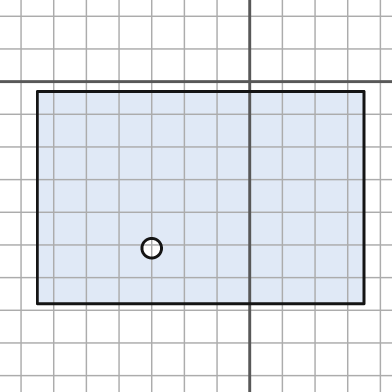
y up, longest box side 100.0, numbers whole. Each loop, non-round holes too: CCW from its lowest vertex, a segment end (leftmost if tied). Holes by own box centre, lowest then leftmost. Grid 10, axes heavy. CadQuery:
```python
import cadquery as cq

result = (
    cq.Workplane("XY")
    .moveTo(-65.0, -68.0)
    .lineTo(35.0, -68.0)
    .lineTo(35.0, -3.0)
    .lineTo(-65.0, -3.0)
    .close()
    .moveTo(-30.0, -51.0)
    .circle(3.0)
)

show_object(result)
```